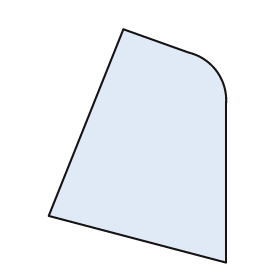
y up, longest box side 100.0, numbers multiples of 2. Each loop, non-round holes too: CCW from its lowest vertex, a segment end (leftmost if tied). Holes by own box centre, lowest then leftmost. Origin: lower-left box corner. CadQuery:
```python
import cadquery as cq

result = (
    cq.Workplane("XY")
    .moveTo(76.0, 0.0)
    .lineTo(76.0, 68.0)
    .threePointArc((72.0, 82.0), (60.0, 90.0))
    .lineTo(32.0, 100.0)
    .lineTo(0.0, 20.0)
    .close()
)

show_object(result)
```